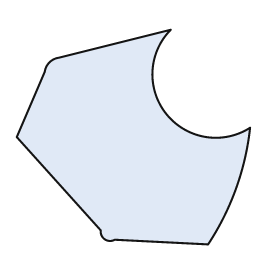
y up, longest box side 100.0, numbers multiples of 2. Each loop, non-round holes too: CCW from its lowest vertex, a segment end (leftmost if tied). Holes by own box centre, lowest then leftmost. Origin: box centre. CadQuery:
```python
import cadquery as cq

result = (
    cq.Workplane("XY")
    .moveTo(32.0, -46.0)
    .threePointArc((44.0, -22.0), (50.0, 4.0))
    .threePointArc((14.0, 10.0), (16.0, 46.0))
    .lineTo(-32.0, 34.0)
    .threePointArc((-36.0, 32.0), (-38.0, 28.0))
    .lineTo(-50.0, 0.0)
    .lineTo(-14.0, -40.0)
    .threePointArc((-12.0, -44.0), (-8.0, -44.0))
    .close()
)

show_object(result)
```